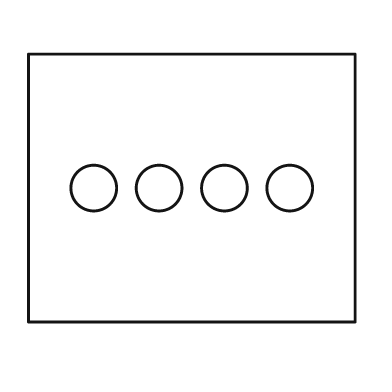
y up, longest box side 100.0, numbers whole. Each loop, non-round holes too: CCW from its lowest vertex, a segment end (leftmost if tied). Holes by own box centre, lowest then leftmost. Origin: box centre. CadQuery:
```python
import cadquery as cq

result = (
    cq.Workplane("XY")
    .moveTo(-50.0, -41.0)
    .lineTo(50.0, -41.0)
    .lineTo(50.0, 41.0)
    .lineTo(-50.0, 41.0)
    .close()
    .moveTo(-30.0, 0.0)
    .circle(7.0)
    .moveTo(-10.0, 0.0)
    .circle(7.0)
    .moveTo(10.0, 0.0)
    .circle(7.0)
    .moveTo(30.0, 0.0)
    .circle(7.0)
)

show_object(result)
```